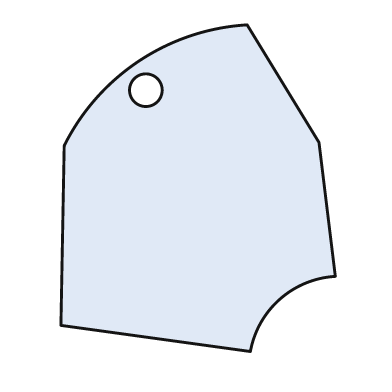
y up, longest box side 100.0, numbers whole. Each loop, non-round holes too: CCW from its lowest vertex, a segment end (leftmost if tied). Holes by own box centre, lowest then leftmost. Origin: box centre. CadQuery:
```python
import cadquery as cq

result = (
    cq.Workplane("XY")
    .moveTo(16.0, -50.0)
    .threePointArc((25.0, -34.0), (42.0, -27.0))
    .lineTo(37.0, 14.0)
    .lineTo(15.0, 50.0)
    .threePointArc((-18.0, 39.0), (-41.0, 13.0))
    .lineTo(-42.0, -42.0)
    .close()
    .moveTo(-16.0, 30.0)
    .circle(5.0)
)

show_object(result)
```